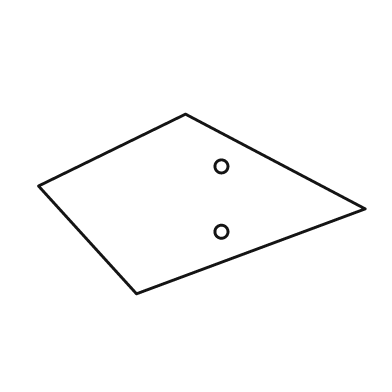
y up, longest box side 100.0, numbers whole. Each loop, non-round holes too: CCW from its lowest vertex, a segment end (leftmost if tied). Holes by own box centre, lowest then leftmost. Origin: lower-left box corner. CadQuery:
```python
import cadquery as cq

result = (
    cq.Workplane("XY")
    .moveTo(30.0, 0.0)
    .lineTo(100.0, 26.0)
    .lineTo(45.0, 55.0)
    .lineTo(0.0, 33.0)
    .close()
    .moveTo(56.0, 19.0)
    .circle(2.0)
    .moveTo(56.0, 39.0)
    .circle(2.0)
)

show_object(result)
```